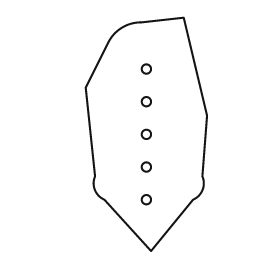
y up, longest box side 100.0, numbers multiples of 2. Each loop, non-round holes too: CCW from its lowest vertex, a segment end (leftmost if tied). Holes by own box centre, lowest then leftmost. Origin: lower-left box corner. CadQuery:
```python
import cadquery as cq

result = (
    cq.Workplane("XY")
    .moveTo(28.0, 0.0)
    .lineTo(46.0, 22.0)
    .threePointArc((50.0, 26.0), (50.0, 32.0))
    .lineTo(52.0, 58.0)
    .lineTo(42.0, 100.0)
    .lineTo(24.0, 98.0)
    .threePointArc((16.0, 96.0), (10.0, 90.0))
    .lineTo(0.0, 70.0)
    .lineTo(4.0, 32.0)
    .threePointArc((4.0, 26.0), (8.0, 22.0))
    .close()
    .moveTo(26.0, 22.0)
    .circle(2.0)
    .moveTo(26.0, 36.0)
    .circle(2.0)
    .moveTo(26.0, 50.0)
    .circle(2.0)
    .moveTo(26.0, 64.0)
    .circle(2.0)
    .moveTo(26.0, 78.0)
    .circle(2.0)
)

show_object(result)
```